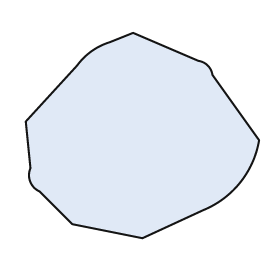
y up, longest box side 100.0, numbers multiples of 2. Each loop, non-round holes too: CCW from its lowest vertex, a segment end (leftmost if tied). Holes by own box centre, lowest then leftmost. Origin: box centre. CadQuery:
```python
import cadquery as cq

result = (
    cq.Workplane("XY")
    .moveTo(0.0, -44.0)
    .lineTo(26.0, -32.0)
    .threePointArc((42.0, -20.0), (50.0, -2.0))
    .lineTo(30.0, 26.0)
    .threePointArc((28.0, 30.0), (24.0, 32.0))
    .lineTo(-4.0, 44.0)
    .lineTo(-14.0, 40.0)
    .threePointArc((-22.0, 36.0), (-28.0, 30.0))
    .lineTo(-50.0, 6.0)
    .lineTo(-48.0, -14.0)
    .threePointArc((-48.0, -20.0), (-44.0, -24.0))
    .lineTo(-30.0, -38.0)
    .close()
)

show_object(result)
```